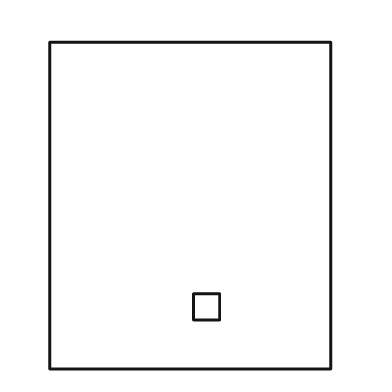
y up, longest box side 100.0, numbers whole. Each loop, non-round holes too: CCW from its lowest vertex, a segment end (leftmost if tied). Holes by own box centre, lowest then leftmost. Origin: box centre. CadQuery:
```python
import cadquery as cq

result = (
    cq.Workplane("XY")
    .moveTo(-43.0, -50.0)
    .lineTo(43.0, -50.0)
    .lineTo(43.0, 50.0)
    .lineTo(-43.0, 50.0)
    .close()
    .moveTo(1.0, -35.0)
    .lineTo(9.0, -35.0)
    .lineTo(9.0, -27.0)
    .lineTo(1.0, -27.0)
    .close()
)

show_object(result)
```